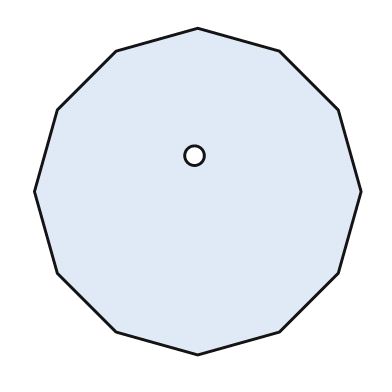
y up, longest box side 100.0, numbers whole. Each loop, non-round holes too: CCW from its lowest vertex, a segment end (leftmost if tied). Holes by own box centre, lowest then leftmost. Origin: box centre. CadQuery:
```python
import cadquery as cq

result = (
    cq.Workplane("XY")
    .moveTo(0.0, -50.0)
    .lineTo(25.0, -43.0)
    .lineTo(43.0, -25.0)
    .lineTo(50.0, 0.0)
    .lineTo(43.0, 25.0)
    .lineTo(25.0, 43.0)
    .lineTo(0.0, 50.0)
    .lineTo(-25.0, 43.0)
    .lineTo(-43.0, 25.0)
    .lineTo(-50.0, 0.0)
    .lineTo(-43.0, -25.0)
    .lineTo(-25.0, -43.0)
    .close()
    .moveTo(-1.0, 11.0)
    .circle(3.0)
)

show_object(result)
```